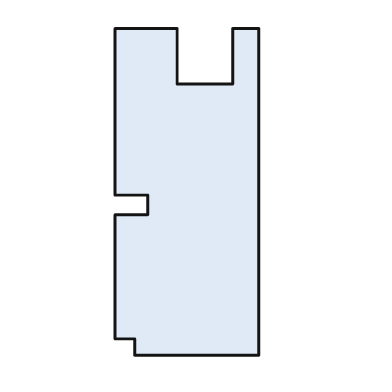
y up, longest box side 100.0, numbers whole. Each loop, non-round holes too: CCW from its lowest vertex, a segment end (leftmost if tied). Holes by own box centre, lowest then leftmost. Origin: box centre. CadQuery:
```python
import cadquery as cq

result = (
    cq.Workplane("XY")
    .moveTo(-16.0, -50.0)
    .lineTo(22.0, -50.0)
    .lineTo(22.0, 50.0)
    .lineTo(14.0, 50.0)
    .lineTo(14.0, 33.0)
    .lineTo(-3.0, 33.0)
    .lineTo(-3.0, 50.0)
    .lineTo(-22.0, 50.0)
    .lineTo(-22.0, -1.0)
    .lineTo(-12.0, -1.0)
    .lineTo(-12.0, -7.0)
    .lineTo(-22.0, -7.0)
    .lineTo(-22.0, -45.0)
    .lineTo(-16.0, -45.0)
    .close()
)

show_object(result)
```